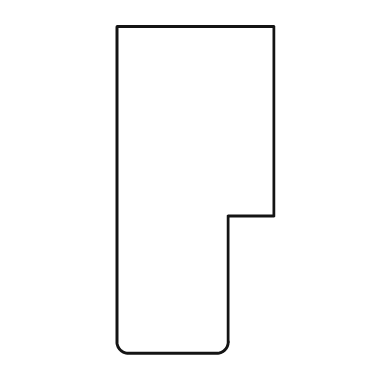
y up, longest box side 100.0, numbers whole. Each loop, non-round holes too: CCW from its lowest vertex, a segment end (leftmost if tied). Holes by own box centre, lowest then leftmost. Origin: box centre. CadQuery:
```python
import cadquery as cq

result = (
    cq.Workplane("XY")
    .moveTo(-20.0, -50.0)
    .lineTo(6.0, -50.0)
    .threePointArc((9.0, -49.0), (10.0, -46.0))
    .lineTo(10.0, -8.0)
    .lineTo(24.0, -8.0)
    .lineTo(24.0, 50.0)
    .lineTo(-24.0, 50.0)
    .lineTo(-24.0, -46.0)
    .threePointArc((-23.0, -49.0), (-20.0, -50.0))
    .close()
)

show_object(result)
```